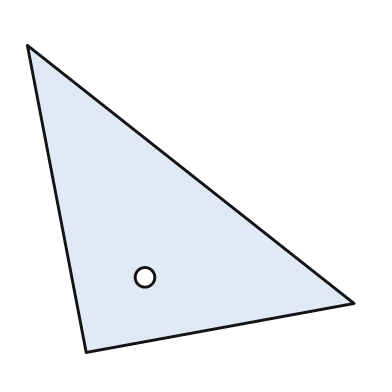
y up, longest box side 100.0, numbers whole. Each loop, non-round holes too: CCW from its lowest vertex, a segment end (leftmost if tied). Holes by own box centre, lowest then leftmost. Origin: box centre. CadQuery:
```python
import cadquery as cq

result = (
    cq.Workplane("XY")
    .moveTo(-32.0, -47.0)
    .lineTo(50.0, -32.0)
    .lineTo(-50.0, 47.0)
    .close()
    .moveTo(-14.0, -24.0)
    .circle(3.0)
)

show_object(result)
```